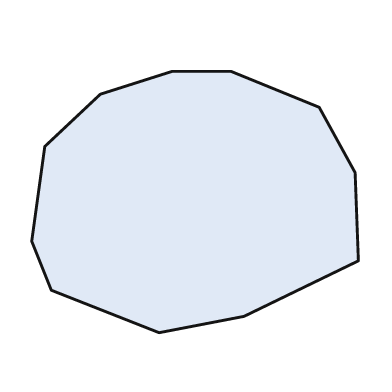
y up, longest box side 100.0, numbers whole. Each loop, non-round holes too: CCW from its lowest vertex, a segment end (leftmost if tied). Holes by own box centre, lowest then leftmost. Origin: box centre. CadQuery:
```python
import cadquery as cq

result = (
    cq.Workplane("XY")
    .moveTo(-11.0, -40.0)
    .lineTo(15.0, -35.0)
    .lineTo(50.0, -18.0)
    .lineTo(49.0, 9.0)
    .lineTo(38.0, 29.0)
    .lineTo(11.0, 40.0)
    .lineTo(-7.0, 40.0)
    .lineTo(-29.0, 33.0)
    .lineTo(-46.0, 17.0)
    .lineTo(-50.0, -12.0)
    .lineTo(-44.0, -27.0)
    .close()
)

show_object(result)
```